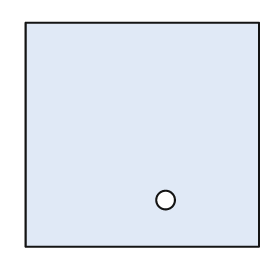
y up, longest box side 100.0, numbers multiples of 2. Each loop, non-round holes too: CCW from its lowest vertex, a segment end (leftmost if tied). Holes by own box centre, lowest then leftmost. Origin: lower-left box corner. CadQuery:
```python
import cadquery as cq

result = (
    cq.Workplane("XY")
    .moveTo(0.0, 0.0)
    .lineTo(100.0, 0.0)
    .lineTo(100.0, 96.0)
    .lineTo(0.0, 96.0)
    .close()
    .moveTo(60.0, 20.0)
    .circle(4.0)
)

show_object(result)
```